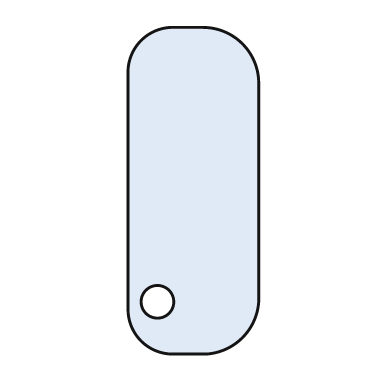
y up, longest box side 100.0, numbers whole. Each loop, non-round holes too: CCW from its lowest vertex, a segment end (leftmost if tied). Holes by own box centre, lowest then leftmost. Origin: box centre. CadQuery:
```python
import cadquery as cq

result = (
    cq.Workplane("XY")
    .moveTo(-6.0, -50.0)
    .lineTo(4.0, -50.0)
    .threePointArc((15.0, -45.0), (20.0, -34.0))
    .lineTo(20.0, 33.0)
    .threePointArc((15.0, 45.0), (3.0, 50.0))
    .lineTo(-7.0, 50.0)
    .threePointArc((-16.0, 46.0), (-20.0, 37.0))
    .lineTo(-20.0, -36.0)
    .threePointArc((-16.0, -46.0), (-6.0, -50.0))
    .close()
    .moveTo(-11.0, -34.0)
    .circle(5.0)
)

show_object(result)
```